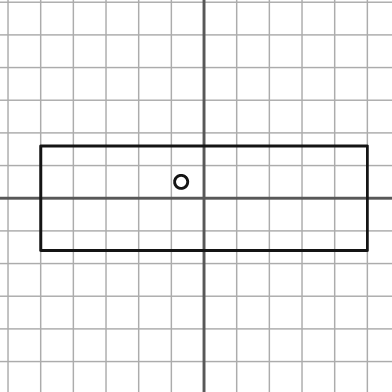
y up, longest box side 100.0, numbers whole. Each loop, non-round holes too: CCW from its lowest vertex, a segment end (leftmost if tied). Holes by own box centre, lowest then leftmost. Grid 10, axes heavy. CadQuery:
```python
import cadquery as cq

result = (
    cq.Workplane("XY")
    .moveTo(-50.0, -16.0)
    .lineTo(50.0, -16.0)
    .lineTo(50.0, 16.0)
    .lineTo(-50.0, 16.0)
    .close()
    .moveTo(-7.0, 5.0)
    .circle(2.0)
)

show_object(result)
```